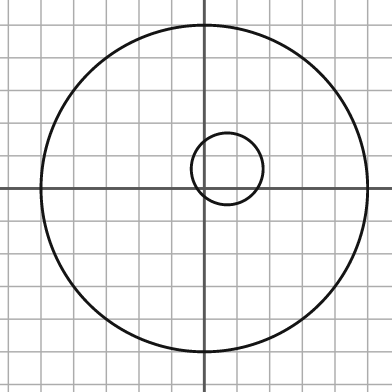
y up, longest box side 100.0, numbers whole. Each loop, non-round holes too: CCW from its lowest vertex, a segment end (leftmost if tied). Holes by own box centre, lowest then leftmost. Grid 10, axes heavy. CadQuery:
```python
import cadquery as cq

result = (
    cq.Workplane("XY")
    .moveTo(0.0, 0.0)
    .circle(50.0)
    .moveTo(7.0, 6.0)
    .circle(11.0)
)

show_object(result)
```